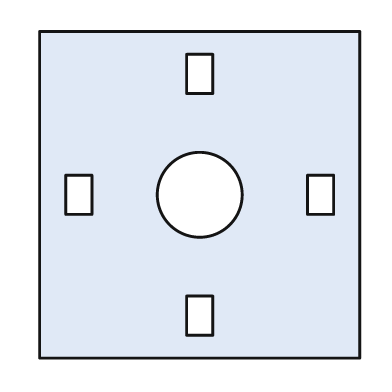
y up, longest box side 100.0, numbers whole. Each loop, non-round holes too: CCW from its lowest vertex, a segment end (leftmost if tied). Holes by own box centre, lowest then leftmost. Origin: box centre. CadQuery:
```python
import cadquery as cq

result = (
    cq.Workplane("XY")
    .moveTo(-49.0, -50.0)
    .lineTo(49.0, -50.0)
    .lineTo(49.0, 50.0)
    .lineTo(-49.0, 50.0)
    .close()
    .moveTo(-4.0, -43.0)
    .lineTo(4.0, -43.0)
    .lineTo(4.0, -31.0)
    .lineTo(-4.0, -31.0)
    .close()
    .moveTo(-41.0, -6.0)
    .lineTo(-33.0, -6.0)
    .lineTo(-33.0, 6.0)
    .lineTo(-41.0, 6.0)
    .close()
    .moveTo(0.0, 0.0)
    .circle(13.0)
    .moveTo(33.0, -6.0)
    .lineTo(41.0, -6.0)
    .lineTo(41.0, 6.0)
    .lineTo(33.0, 6.0)
    .close()
    .moveTo(-4.0, 31.0)
    .lineTo(4.0, 31.0)
    .lineTo(4.0, 43.0)
    .lineTo(-4.0, 43.0)
    .close()
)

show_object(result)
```